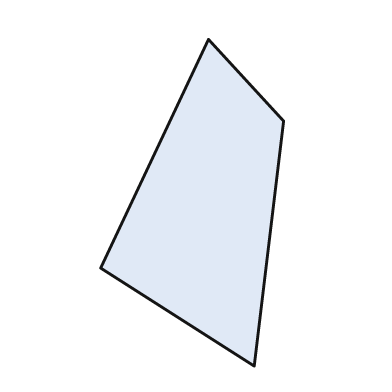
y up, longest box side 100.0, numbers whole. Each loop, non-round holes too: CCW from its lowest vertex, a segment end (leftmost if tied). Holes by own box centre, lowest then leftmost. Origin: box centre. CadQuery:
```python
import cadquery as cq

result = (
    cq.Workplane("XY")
    .moveTo(19.0, -50.0)
    .lineTo(28.0, 25.0)
    .lineTo(5.0, 50.0)
    .lineTo(-28.0, -20.0)
    .close()
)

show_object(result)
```